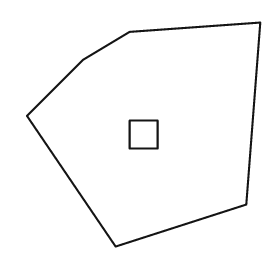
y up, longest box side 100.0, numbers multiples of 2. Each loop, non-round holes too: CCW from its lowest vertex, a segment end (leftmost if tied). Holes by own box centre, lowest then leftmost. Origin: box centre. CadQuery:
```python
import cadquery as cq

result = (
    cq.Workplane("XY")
    .moveTo(-12.0, -48.0)
    .lineTo(44.0, -30.0)
    .lineTo(50.0, 48.0)
    .lineTo(-6.0, 44.0)
    .lineTo(-26.0, 32.0)
    .lineTo(-50.0, 8.0)
    .close()
    .moveTo(-6.0, -6.0)
    .lineTo(6.0, -6.0)
    .lineTo(6.0, 6.0)
    .lineTo(-6.0, 6.0)
    .close()
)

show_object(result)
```